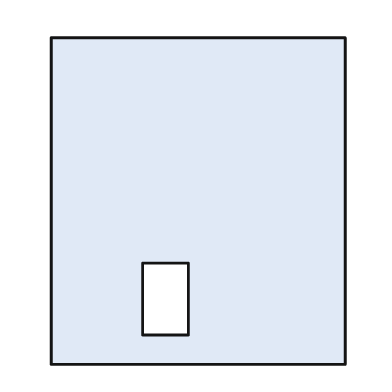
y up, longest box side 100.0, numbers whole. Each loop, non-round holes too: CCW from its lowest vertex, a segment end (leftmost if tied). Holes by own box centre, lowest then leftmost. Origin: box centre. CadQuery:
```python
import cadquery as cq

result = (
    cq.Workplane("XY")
    .moveTo(-45.0, -50.0)
    .lineTo(45.0, -50.0)
    .lineTo(45.0, 50.0)
    .lineTo(-45.0, 50.0)
    .close()
    .moveTo(-17.0, -41.0)
    .lineTo(-3.0, -41.0)
    .lineTo(-3.0, -19.0)
    .lineTo(-17.0, -19.0)
    .close()
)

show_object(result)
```